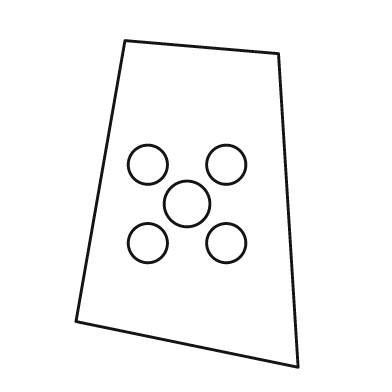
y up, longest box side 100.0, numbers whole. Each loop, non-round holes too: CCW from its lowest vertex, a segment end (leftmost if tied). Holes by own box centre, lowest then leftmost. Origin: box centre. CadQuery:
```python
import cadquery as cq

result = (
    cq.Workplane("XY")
    .moveTo(34.0, -50.0)
    .lineTo(28.0, 46.0)
    .lineTo(-19.0, 50.0)
    .lineTo(-34.0, -36.0)
    .close()
    .moveTo(-12.0, -12.0)
    .circle(6.0)
    .moveTo(12.0, -12.0)
    .circle(6.0)
    .moveTo(0.0, 0.0)
    .circle(7.0)
    .moveTo(-12.0, 12.0)
    .circle(6.0)
    .moveTo(12.0, 12.0)
    .circle(6.0)
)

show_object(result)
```